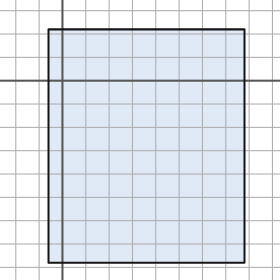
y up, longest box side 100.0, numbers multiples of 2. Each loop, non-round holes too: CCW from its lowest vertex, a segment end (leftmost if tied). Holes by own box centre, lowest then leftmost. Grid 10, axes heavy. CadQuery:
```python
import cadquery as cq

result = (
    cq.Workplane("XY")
    .moveTo(-6.0, -78.0)
    .lineTo(78.0, -78.0)
    .lineTo(78.0, 22.0)
    .lineTo(-6.0, 22.0)
    .close()
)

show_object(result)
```